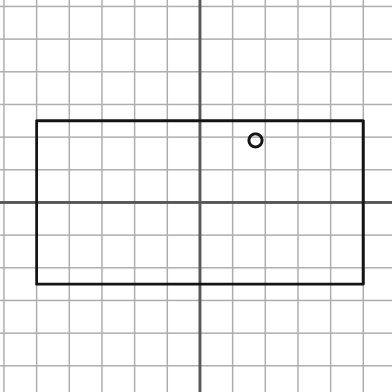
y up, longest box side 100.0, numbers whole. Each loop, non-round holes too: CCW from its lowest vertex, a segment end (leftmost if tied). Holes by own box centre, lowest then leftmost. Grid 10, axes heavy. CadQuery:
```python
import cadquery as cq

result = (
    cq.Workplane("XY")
    .moveTo(-50.0, -25.0)
    .lineTo(50.0, -25.0)
    .lineTo(50.0, 25.0)
    .lineTo(-50.0, 25.0)
    .close()
    .moveTo(17.0, 19.0)
    .circle(2.0)
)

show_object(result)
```